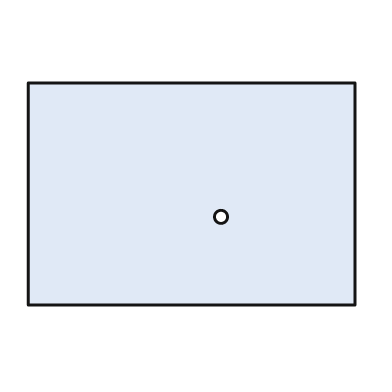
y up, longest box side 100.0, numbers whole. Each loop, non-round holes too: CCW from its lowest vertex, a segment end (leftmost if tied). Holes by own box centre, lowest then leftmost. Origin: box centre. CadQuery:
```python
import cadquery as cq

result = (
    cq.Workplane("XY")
    .moveTo(-50.0, -34.0)
    .lineTo(50.0, -34.0)
    .lineTo(50.0, 34.0)
    .lineTo(-50.0, 34.0)
    .close()
    .moveTo(9.0, -7.0)
    .circle(2.0)
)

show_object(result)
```